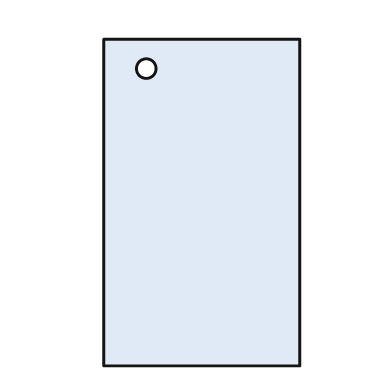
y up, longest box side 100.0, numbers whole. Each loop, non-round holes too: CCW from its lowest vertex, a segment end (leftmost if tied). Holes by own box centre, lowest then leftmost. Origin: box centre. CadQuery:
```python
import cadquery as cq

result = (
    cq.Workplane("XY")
    .moveTo(-30.0, -50.0)
    .lineTo(30.0, -50.0)
    .lineTo(30.0, 50.0)
    .lineTo(-30.0, 50.0)
    .close()
    .moveTo(-17.0, 41.0)
    .circle(3.0)
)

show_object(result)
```